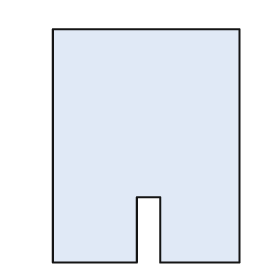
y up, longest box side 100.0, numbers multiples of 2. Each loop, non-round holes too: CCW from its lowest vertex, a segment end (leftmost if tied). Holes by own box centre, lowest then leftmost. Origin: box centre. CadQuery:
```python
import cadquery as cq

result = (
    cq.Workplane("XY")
    .moveTo(-40.0, -50.0)
    .lineTo(-4.0, -50.0)
    .lineTo(-4.0, -22.0)
    .lineTo(6.0, -22.0)
    .lineTo(6.0, -50.0)
    .lineTo(40.0, -50.0)
    .lineTo(40.0, 50.0)
    .lineTo(-40.0, 50.0)
    .close()
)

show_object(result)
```